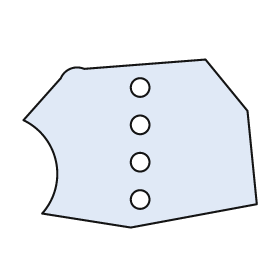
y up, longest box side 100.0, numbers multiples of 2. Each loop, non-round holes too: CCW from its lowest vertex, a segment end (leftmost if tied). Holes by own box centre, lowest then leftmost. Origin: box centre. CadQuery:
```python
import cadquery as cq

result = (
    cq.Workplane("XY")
    .moveTo(-4.0, -36.0)
    .lineTo(50.0, -26.0)
    .lineTo(46.0, 14.0)
    .lineTo(28.0, 36.0)
    .lineTo(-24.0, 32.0)
    .threePointArc((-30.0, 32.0), (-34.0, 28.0))
    .lineTo(-50.0, 10.0)
    .threePointArc((-36.0, -8.0), (-42.0, -30.0))
    .close()
    .moveTo(0.0, -24.0)
    .circle(4.0)
    .moveTo(0.0, -8.0)
    .circle(4.0)
    .moveTo(0.0, 8.0)
    .circle(4.0)
    .moveTo(0.0, 24.0)
    .circle(4.0)
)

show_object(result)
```